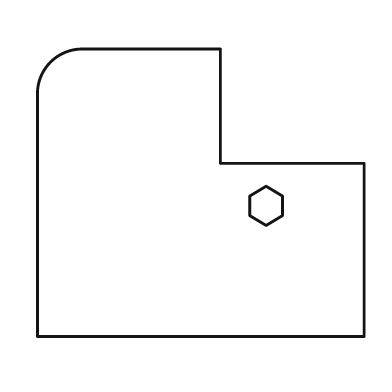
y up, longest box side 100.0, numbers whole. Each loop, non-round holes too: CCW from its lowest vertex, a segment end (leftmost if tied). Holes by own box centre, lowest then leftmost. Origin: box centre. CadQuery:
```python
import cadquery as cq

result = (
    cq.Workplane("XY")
    .moveTo(-50.0, -44.0)
    .lineTo(50.0, -44.0)
    .lineTo(50.0, 9.0)
    .lineTo(6.0, 9.0)
    .lineTo(6.0, 44.0)
    .lineTo(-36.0, 44.0)
    .threePointArc((-46.0, 40.0), (-50.0, 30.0))
    .close()
    .moveTo(20.0, -10.0)
    .lineTo(25.0, -7.0)
    .lineTo(25.0, -1.0)
    .lineTo(20.0, 2.0)
    .lineTo(15.0, -1.0)
    .lineTo(15.0, -7.0)
    .close()
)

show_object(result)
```